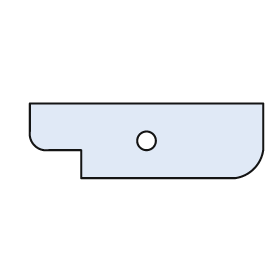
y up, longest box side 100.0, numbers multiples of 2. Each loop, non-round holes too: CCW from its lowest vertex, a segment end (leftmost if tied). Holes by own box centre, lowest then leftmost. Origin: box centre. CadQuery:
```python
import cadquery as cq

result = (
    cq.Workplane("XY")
    .moveTo(-28.0, -16.0)
    .lineTo(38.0, -16.0)
    .threePointArc((46.0, -12.0), (50.0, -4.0))
    .lineTo(50.0, 16.0)
    .lineTo(-50.0, 16.0)
    .lineTo(-50.0, 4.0)
    .threePointArc((-48.0, -2.0), (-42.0, -4.0))
    .lineTo(-28.0, -4.0)
    .close()
    .moveTo(0.0, 0.0)
    .circle(4.0)
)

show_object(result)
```